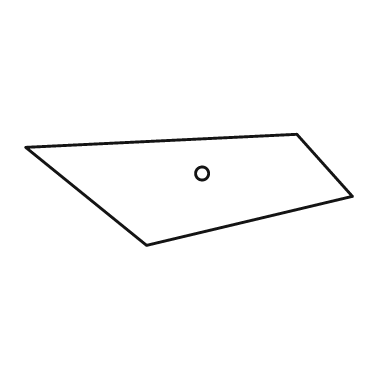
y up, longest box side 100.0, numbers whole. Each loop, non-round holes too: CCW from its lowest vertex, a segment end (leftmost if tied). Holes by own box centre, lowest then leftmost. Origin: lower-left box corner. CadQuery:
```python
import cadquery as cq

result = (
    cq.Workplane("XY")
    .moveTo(37.0, 0.0)
    .lineTo(100.0, 15.0)
    .lineTo(83.0, 34.0)
    .lineTo(0.0, 30.0)
    .close()
    .moveTo(54.0, 22.0)
    .circle(2.0)
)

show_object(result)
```